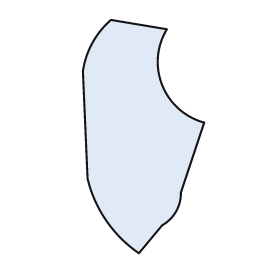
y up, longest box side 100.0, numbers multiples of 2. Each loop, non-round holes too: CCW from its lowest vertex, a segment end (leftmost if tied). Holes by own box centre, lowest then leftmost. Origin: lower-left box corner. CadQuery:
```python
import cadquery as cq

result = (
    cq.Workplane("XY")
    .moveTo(24.0, 0.0)
    .lineTo(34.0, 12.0)
    .threePointArc((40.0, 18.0), (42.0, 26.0))
    .lineTo(52.0, 56.0)
    .threePointArc((34.0, 72.0), (36.0, 96.0))
    .lineTo(12.0, 100.0)
    .threePointArc((4.0, 90.0), (0.0, 78.0))
    .lineTo(2.0, 32.0)
    .threePointArc((10.0, 14.0), (24.0, 0.0))
    .close()
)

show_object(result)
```